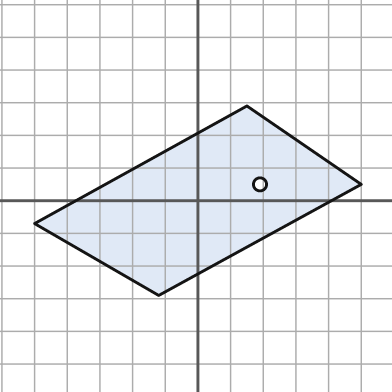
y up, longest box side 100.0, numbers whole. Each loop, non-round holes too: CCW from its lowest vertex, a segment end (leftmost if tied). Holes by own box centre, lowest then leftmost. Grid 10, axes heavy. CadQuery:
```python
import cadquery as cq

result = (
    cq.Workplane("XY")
    .moveTo(-12.0, -29.0)
    .lineTo(50.0, 5.0)
    .lineTo(15.0, 29.0)
    .lineTo(-50.0, -7.0)
    .close()
    .moveTo(19.0, 5.0)
    .circle(2.0)
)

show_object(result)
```